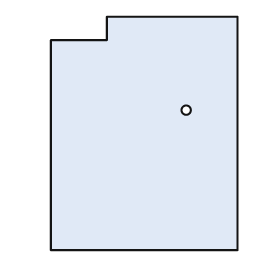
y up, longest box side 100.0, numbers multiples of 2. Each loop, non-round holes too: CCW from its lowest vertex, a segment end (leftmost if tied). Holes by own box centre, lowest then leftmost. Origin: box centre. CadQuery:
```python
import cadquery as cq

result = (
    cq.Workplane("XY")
    .moveTo(-40.0, -50.0)
    .lineTo(40.0, -50.0)
    .lineTo(40.0, 50.0)
    .lineTo(-16.0, 50.0)
    .lineTo(-16.0, 40.0)
    .lineTo(-40.0, 40.0)
    .close()
    .moveTo(18.0, 10.0)
    .circle(2.0)
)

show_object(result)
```